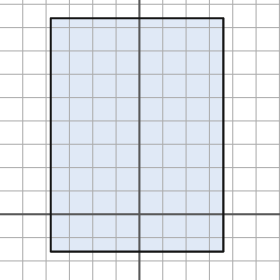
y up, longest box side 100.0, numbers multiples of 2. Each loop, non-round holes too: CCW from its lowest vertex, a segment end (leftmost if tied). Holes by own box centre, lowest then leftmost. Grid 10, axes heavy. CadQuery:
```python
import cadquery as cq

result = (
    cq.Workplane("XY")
    .moveTo(-38.0, -16.0)
    .lineTo(36.0, -16.0)
    .lineTo(36.0, 84.0)
    .lineTo(-38.0, 84.0)
    .close()
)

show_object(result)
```